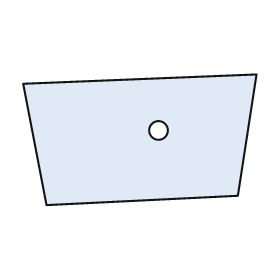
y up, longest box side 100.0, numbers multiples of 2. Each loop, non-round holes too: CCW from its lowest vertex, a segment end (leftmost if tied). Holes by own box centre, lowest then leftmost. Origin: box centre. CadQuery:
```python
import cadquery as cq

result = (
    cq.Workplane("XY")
    .moveTo(-40.0, -28.0)
    .lineTo(42.0, -24.0)
    .lineTo(50.0, 28.0)
    .lineTo(-50.0, 24.0)
    .close()
    .moveTo(8.0, 4.0)
    .circle(4.0)
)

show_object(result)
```